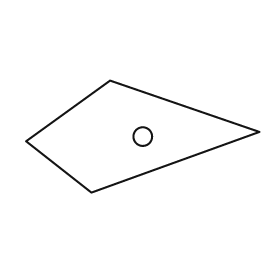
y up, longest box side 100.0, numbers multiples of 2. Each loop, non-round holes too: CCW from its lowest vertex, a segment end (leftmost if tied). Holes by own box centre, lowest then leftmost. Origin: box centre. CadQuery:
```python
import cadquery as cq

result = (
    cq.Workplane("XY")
    .moveTo(-22.0, -24.0)
    .lineTo(50.0, 2.0)
    .lineTo(-14.0, 24.0)
    .lineTo(-50.0, -2.0)
    .close()
    .moveTo(0.0, 0.0)
    .circle(4.0)
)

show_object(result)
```